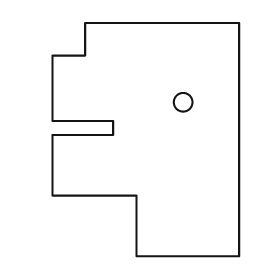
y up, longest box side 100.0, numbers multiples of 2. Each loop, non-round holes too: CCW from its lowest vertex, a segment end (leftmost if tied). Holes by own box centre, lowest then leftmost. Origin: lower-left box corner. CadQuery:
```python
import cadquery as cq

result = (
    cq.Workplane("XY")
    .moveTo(36.0, 0.0)
    .lineTo(80.0, 0.0)
    .lineTo(80.0, 100.0)
    .lineTo(14.0, 100.0)
    .lineTo(14.0, 86.0)
    .lineTo(0.0, 86.0)
    .lineTo(0.0, 58.0)
    .lineTo(26.0, 58.0)
    .lineTo(26.0, 52.0)
    .lineTo(0.0, 52.0)
    .lineTo(0.0, 26.0)
    .lineTo(36.0, 26.0)
    .close()
    .moveTo(56.0, 66.0)
    .circle(4.0)
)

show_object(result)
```